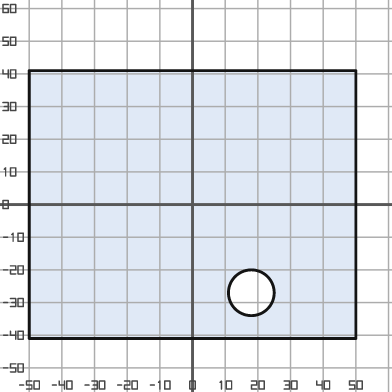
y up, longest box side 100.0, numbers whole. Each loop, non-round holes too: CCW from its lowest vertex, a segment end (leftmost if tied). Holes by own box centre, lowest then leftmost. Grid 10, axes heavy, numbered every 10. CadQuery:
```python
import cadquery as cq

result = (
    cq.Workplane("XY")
    .moveTo(-50.0, -41.0)
    .lineTo(50.0, -41.0)
    .lineTo(50.0, 41.0)
    .lineTo(-50.0, 41.0)
    .close()
    .moveTo(18.0, -27.0)
    .circle(7.0)
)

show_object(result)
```